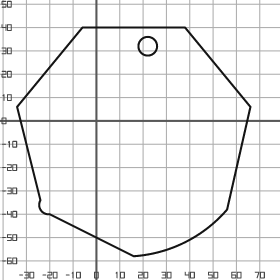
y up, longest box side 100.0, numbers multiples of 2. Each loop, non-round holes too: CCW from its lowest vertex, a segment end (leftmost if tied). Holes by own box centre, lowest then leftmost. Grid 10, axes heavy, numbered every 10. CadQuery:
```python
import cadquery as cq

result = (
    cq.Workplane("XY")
    .moveTo(16.0, -58.0)
    .threePointArc((38.0, -52.0), (56.0, -38.0))
    .lineTo(66.0, 6.0)
    .lineTo(38.0, 40.0)
    .lineTo(-6.0, 40.0)
    .lineTo(-34.0, 6.0)
    .lineTo(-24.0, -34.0)
    .threePointArc((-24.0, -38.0), (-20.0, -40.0))
    .close()
    .moveTo(22.0, 32.0)
    .circle(4.0)
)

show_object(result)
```